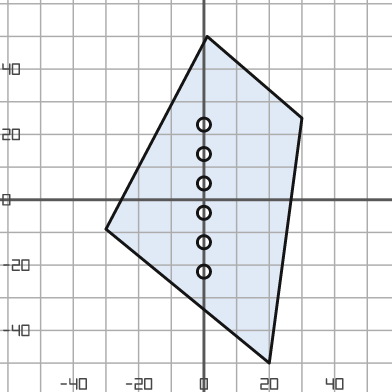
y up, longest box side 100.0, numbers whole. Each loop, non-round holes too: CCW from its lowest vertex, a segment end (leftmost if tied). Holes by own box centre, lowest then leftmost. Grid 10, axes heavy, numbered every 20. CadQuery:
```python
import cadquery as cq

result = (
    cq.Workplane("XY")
    .moveTo(20.0, -50.0)
    .lineTo(30.0, 25.0)
    .lineTo(1.0, 50.0)
    .lineTo(-30.0, -9.0)
    .close()
    .moveTo(0.0, -22.0)
    .circle(2.0)
    .moveTo(0.0, -13.0)
    .circle(2.0)
    .moveTo(0.0, -4.0)
    .circle(2.0)
    .moveTo(0.0, 5.0)
    .circle(2.0)
    .moveTo(0.0, 14.0)
    .circle(2.0)
    .moveTo(0.0, 23.0)
    .circle(2.0)
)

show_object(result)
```